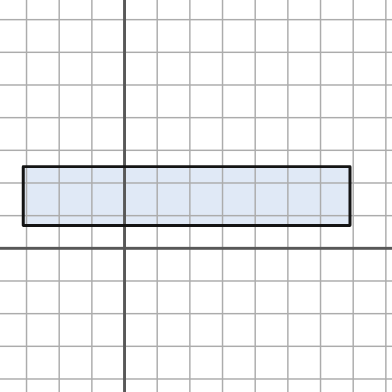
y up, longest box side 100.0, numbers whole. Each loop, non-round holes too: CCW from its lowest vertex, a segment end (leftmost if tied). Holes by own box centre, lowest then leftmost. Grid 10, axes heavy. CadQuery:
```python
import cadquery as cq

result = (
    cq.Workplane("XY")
    .moveTo(-31.0, 7.0)
    .lineTo(69.0, 7.0)
    .lineTo(69.0, 25.0)
    .lineTo(-31.0, 25.0)
    .close()
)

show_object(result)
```